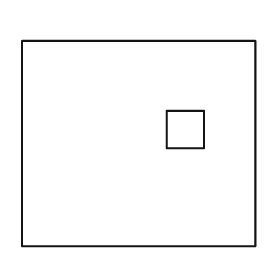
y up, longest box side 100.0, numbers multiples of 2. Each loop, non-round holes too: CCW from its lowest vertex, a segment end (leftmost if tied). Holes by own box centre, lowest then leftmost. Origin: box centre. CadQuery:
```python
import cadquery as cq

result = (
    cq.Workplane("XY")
    .moveTo(-50.0, -44.0)
    .lineTo(50.0, -44.0)
    .lineTo(50.0, 44.0)
    .lineTo(-50.0, 44.0)
    .close()
    .moveTo(12.0, -2.0)
    .lineTo(28.0, -2.0)
    .lineTo(28.0, 14.0)
    .lineTo(12.0, 14.0)
    .close()
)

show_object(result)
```